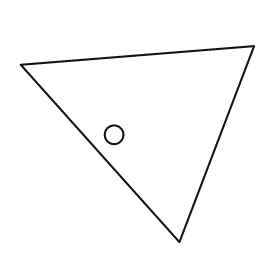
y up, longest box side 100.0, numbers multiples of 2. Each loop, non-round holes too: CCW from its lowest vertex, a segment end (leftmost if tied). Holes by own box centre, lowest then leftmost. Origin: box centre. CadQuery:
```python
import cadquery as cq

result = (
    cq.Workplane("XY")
    .moveTo(18.0, -42.0)
    .lineTo(50.0, 42.0)
    .lineTo(-50.0, 34.0)
    .close()
    .moveTo(-10.0, 4.0)
    .circle(4.0)
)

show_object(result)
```